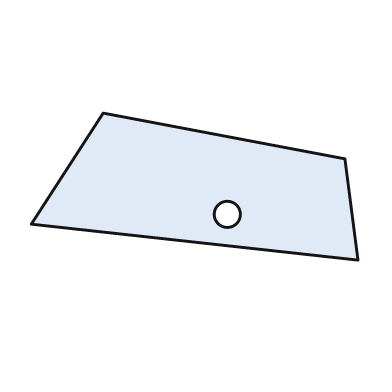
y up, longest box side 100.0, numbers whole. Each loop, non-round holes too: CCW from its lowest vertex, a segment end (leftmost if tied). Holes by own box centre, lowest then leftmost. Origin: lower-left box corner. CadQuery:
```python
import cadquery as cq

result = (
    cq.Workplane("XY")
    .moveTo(100.0, 0.0)
    .lineTo(96.0, 31.0)
    .lineTo(22.0, 45.0)
    .lineTo(0.0, 11.0)
    .close()
    .moveTo(60.0, 14.0)
    .circle(4.0)
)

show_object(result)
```